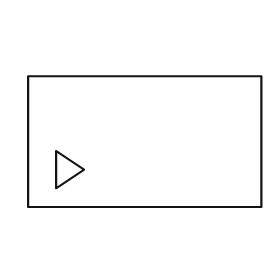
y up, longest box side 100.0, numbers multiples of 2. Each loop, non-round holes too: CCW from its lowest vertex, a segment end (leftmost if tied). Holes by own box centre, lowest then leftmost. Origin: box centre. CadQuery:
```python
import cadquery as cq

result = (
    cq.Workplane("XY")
    .moveTo(-50.0, -28.0)
    .lineTo(50.0, -28.0)
    .lineTo(50.0, 28.0)
    .lineTo(-50.0, 28.0)
    .close()
    .moveTo(-38.0, -20.0)
    .lineTo(-26.0, -12.0)
    .lineTo(-38.0, -4.0)
    .close()
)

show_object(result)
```